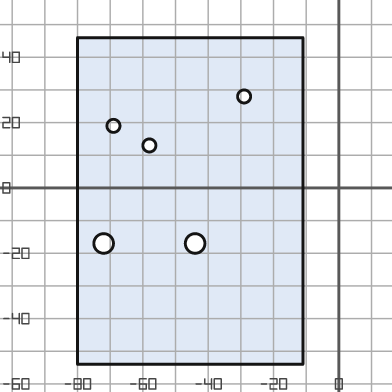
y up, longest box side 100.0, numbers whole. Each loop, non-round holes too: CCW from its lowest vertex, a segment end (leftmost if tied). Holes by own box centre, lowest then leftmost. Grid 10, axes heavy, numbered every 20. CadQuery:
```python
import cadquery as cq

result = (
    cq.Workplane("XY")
    .moveTo(-80.0, -54.0)
    .lineTo(-11.0, -54.0)
    .lineTo(-11.0, 46.0)
    .lineTo(-80.0, 46.0)
    .close()
    .moveTo(-72.0, -17.0)
    .circle(3.0)
    .moveTo(-44.0, -17.0)
    .circle(3.0)
    .moveTo(-58.0, 13.0)
    .circle(2.0)
    .moveTo(-69.0, 19.0)
    .circle(2.0)
    .moveTo(-29.0, 28.0)
    .circle(2.0)
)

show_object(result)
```